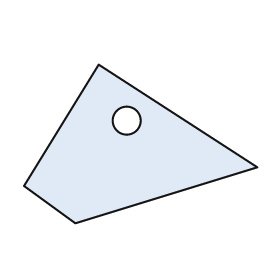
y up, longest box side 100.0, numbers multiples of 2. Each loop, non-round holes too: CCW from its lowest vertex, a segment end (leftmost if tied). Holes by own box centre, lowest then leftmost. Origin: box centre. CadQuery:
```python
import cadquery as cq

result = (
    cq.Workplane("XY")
    .moveTo(-28.0, -34.0)
    .lineTo(50.0, -10.0)
    .lineTo(-18.0, 34.0)
    .lineTo(-50.0, -18.0)
    .close()
    .moveTo(-6.0, 10.0)
    .circle(6.0)
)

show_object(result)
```